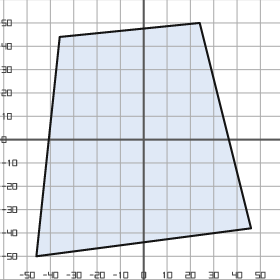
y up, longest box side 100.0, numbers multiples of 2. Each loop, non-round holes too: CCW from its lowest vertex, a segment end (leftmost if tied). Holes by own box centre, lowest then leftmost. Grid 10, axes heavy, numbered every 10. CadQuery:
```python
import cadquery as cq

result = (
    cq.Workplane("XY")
    .moveTo(-46.0, -50.0)
    .lineTo(46.0, -38.0)
    .lineTo(24.0, 50.0)
    .lineTo(-36.0, 44.0)
    .close()
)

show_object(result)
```